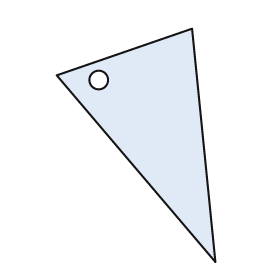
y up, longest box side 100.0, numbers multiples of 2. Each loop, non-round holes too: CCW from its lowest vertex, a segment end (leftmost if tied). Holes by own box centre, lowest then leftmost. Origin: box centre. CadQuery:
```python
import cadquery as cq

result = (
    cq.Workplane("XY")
    .moveTo(34.0, -50.0)
    .lineTo(24.0, 50.0)
    .lineTo(-34.0, 30.0)
    .close()
    .moveTo(-16.0, 28.0)
    .circle(4.0)
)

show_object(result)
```